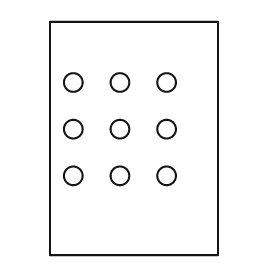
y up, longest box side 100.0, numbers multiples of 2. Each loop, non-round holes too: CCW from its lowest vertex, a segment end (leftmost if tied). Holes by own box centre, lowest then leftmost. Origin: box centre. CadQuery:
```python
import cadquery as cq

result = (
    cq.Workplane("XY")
    .moveTo(-36.0, -50.0)
    .lineTo(36.0, -50.0)
    .lineTo(36.0, 50.0)
    .lineTo(-36.0, 50.0)
    .close()
    .moveTo(-26.0, -16.0)
    .circle(4.0)
    .moveTo(-6.0, -16.0)
    .circle(4.0)
    .moveTo(14.0, -16.0)
    .circle(4.0)
    .moveTo(-26.0, 4.0)
    .circle(4.0)
    .moveTo(-6.0, 4.0)
    .circle(4.0)
    .moveTo(14.0, 4.0)
    .circle(4.0)
    .moveTo(-26.0, 24.0)
    .circle(4.0)
    .moveTo(-6.0, 24.0)
    .circle(4.0)
    .moveTo(14.0, 24.0)
    .circle(4.0)
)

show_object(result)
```